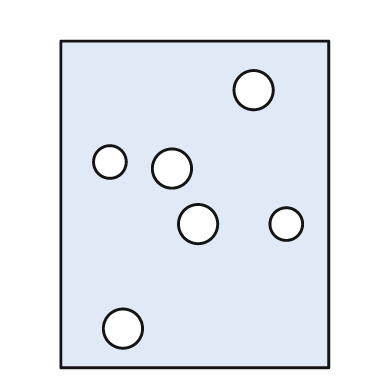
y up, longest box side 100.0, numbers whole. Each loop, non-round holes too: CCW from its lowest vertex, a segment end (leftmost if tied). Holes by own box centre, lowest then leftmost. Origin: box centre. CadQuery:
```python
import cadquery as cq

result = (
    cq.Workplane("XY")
    .moveTo(-41.0, -50.0)
    .lineTo(41.0, -50.0)
    .lineTo(41.0, 50.0)
    .lineTo(-41.0, 50.0)
    .close()
    .moveTo(-22.0, -38.0)
    .circle(6.0)
    .moveTo(1.0, -6.0)
    .circle(6.0)
    .moveTo(28.0, -6.0)
    .circle(5.0)
    .moveTo(-7.0, 11.0)
    .circle(6.0)
    .moveTo(-26.0, 13.0)
    .circle(5.0)
    .moveTo(18.0, 35.0)
    .circle(6.0)
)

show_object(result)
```